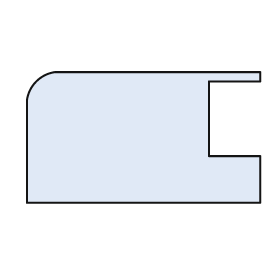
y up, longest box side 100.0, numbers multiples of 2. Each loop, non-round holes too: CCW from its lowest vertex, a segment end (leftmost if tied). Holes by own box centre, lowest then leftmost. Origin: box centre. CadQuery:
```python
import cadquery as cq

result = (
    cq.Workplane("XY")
    .moveTo(-50.0, -28.0)
    .lineTo(50.0, -28.0)
    .lineTo(50.0, -8.0)
    .lineTo(28.0, -8.0)
    .lineTo(28.0, 24.0)
    .lineTo(50.0, 24.0)
    .lineTo(50.0, 28.0)
    .lineTo(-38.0, 28.0)
    .threePointArc((-46.0, 24.0), (-50.0, 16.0))
    .close()
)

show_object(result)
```